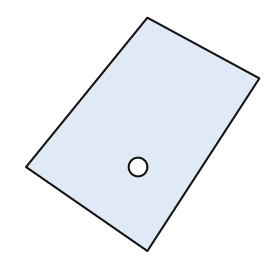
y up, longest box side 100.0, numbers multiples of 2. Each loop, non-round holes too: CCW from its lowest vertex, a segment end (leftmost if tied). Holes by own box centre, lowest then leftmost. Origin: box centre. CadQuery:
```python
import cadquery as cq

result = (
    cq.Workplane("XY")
    .moveTo(2.0, -50.0)
    .lineTo(50.0, 24.0)
    .lineTo(2.0, 50.0)
    .lineTo(-50.0, -14.0)
    .close()
    .moveTo(-2.0, -14.0)
    .circle(4.0)
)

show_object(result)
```